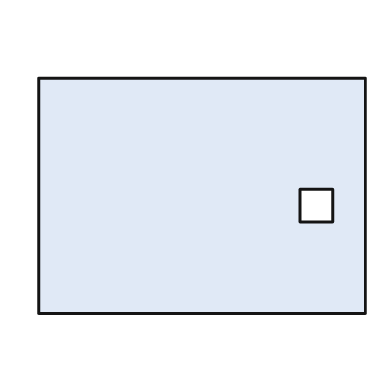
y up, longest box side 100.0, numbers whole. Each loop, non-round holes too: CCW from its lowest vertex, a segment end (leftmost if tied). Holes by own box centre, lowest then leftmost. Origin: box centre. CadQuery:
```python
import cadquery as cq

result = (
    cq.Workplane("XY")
    .moveTo(-50.0, -36.0)
    .lineTo(50.0, -36.0)
    .lineTo(50.0, 36.0)
    .lineTo(-50.0, 36.0)
    .close()
    .moveTo(30.0, -8.0)
    .lineTo(40.0, -8.0)
    .lineTo(40.0, 2.0)
    .lineTo(30.0, 2.0)
    .close()
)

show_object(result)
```